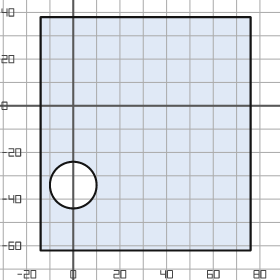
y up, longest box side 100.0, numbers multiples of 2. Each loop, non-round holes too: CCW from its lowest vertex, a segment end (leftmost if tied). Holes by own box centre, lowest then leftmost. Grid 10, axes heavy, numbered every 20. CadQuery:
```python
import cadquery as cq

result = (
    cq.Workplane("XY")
    .moveTo(-14.0, -62.0)
    .lineTo(76.0, -62.0)
    .lineTo(76.0, 38.0)
    .lineTo(-14.0, 38.0)
    .close()
    .moveTo(0.0, -34.0)
    .circle(10.0)
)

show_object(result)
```